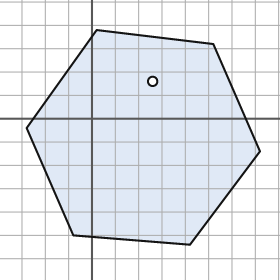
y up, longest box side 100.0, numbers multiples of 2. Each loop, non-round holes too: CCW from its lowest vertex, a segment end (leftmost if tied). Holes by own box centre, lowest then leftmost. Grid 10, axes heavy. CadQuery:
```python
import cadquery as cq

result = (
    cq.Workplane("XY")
    .moveTo(42.0, -54.0)
    .lineTo(72.0, -14.0)
    .lineTo(52.0, 32.0)
    .lineTo(2.0, 38.0)
    .lineTo(-28.0, -4.0)
    .lineTo(-8.0, -50.0)
    .close()
    .moveTo(26.0, 16.0)
    .circle(2.0)
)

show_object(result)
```